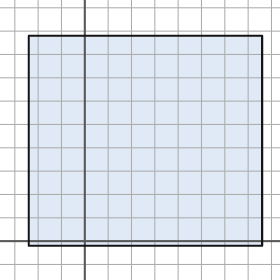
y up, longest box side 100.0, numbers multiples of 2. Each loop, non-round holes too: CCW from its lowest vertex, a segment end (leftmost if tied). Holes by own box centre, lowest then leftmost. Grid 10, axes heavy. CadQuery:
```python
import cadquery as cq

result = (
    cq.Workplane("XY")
    .moveTo(-24.0, -2.0)
    .lineTo(76.0, -2.0)
    .lineTo(76.0, 88.0)
    .lineTo(-24.0, 88.0)
    .close()
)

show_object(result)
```